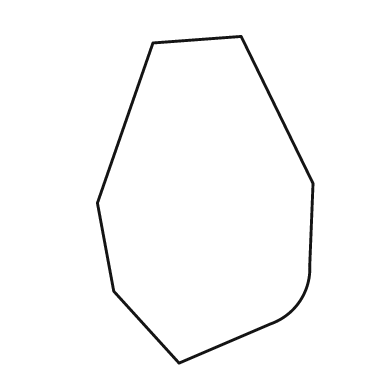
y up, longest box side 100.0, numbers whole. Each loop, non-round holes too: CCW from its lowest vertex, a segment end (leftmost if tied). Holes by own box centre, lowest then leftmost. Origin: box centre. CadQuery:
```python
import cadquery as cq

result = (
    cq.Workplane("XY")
    .moveTo(-8.0, -50.0)
    .lineTo(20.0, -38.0)
    .threePointArc((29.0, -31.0), (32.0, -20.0))
    .lineTo(33.0, 5.0)
    .lineTo(11.0, 50.0)
    .lineTo(-16.0, 48.0)
    .lineTo(-33.0, -1.0)
    .lineTo(-28.0, -28.0)
    .close()
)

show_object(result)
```